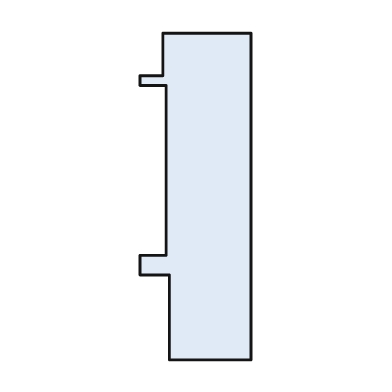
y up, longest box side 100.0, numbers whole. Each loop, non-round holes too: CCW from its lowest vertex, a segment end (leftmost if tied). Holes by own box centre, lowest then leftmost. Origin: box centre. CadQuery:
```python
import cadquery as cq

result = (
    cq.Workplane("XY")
    .moveTo(-8.0, -50.0)
    .lineTo(17.0, -50.0)
    .lineTo(17.0, 50.0)
    .lineTo(-10.0, 50.0)
    .lineTo(-10.0, 37.0)
    .lineTo(-17.0, 37.0)
    .lineTo(-17.0, 34.0)
    .lineTo(-9.0, 34.0)
    .lineTo(-9.0, -18.0)
    .lineTo(-17.0, -18.0)
    .lineTo(-17.0, -24.0)
    .lineTo(-8.0, -24.0)
    .close()
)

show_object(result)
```